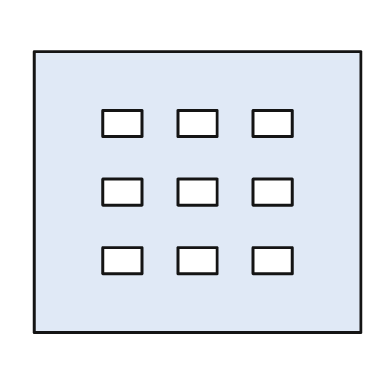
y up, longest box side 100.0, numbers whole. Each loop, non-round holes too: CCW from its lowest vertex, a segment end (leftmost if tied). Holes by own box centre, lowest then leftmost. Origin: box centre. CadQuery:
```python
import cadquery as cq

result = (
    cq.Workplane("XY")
    .moveTo(-50.0, -43.0)
    .lineTo(50.0, -43.0)
    .lineTo(50.0, 43.0)
    .lineTo(-50.0, 43.0)
    .close()
    .moveTo(-29.0, -25.0)
    .lineTo(-17.0, -25.0)
    .lineTo(-17.0, -17.0)
    .lineTo(-29.0, -17.0)
    .close()
    .moveTo(-6.0, -25.0)
    .lineTo(6.0, -25.0)
    .lineTo(6.0, -17.0)
    .lineTo(-6.0, -17.0)
    .close()
    .moveTo(17.0, -25.0)
    .lineTo(29.0, -25.0)
    .lineTo(29.0, -17.0)
    .lineTo(17.0, -17.0)
    .close()
    .moveTo(-29.0, -4.0)
    .lineTo(-17.0, -4.0)
    .lineTo(-17.0, 4.0)
    .lineTo(-29.0, 4.0)
    .close()
    .moveTo(-6.0, -4.0)
    .lineTo(6.0, -4.0)
    .lineTo(6.0, 4.0)
    .lineTo(-6.0, 4.0)
    .close()
    .moveTo(17.0, -4.0)
    .lineTo(29.0, -4.0)
    .lineTo(29.0, 4.0)
    .lineTo(17.0, 4.0)
    .close()
    .moveTo(-29.0, 17.0)
    .lineTo(-17.0, 17.0)
    .lineTo(-17.0, 25.0)
    .lineTo(-29.0, 25.0)
    .close()
    .moveTo(-6.0, 17.0)
    .lineTo(6.0, 17.0)
    .lineTo(6.0, 25.0)
    .lineTo(-6.0, 25.0)
    .close()
    .moveTo(17.0, 17.0)
    .lineTo(29.0, 17.0)
    .lineTo(29.0, 25.0)
    .lineTo(17.0, 25.0)
    .close()
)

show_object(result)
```